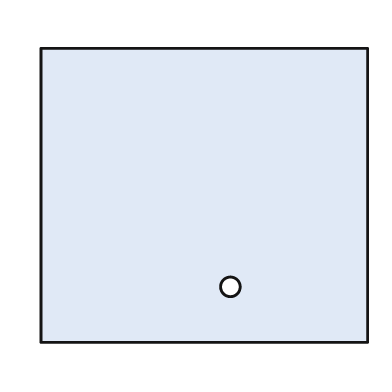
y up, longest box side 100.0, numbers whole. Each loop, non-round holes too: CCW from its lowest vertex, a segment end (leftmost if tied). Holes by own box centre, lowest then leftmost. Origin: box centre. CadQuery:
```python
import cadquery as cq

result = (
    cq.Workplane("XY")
    .moveTo(-50.0, -45.0)
    .lineTo(50.0, -45.0)
    .lineTo(50.0, 45.0)
    .lineTo(-50.0, 45.0)
    .close()
    .moveTo(8.0, -28.0)
    .circle(3.0)
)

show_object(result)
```